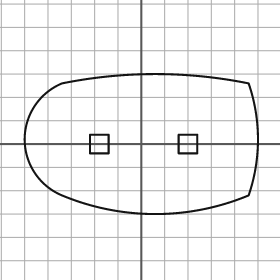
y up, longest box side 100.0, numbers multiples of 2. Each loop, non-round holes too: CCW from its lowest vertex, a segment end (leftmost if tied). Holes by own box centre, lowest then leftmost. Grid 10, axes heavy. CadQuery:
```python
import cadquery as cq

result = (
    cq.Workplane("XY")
    .moveTo(-34.0, -22.0)
    .threePointArc((6.0, -30.0), (46.0, -22.0))
    .threePointArc((50.0, 2.0), (46.0, 26.0))
    .threePointArc((6.0, 30.0), (-34.0, 26.0))
    .threePointArc((-50.0, 2.0), (-34.0, -22.0))
    .close()
    .moveTo(-22.0, -4.0)
    .lineTo(-14.0, -4.0)
    .lineTo(-14.0, 4.0)
    .lineTo(-22.0, 4.0)
    .close()
    .moveTo(16.0, -4.0)
    .lineTo(24.0, -4.0)
    .lineTo(24.0, 4.0)
    .lineTo(16.0, 4.0)
    .close()
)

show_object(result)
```